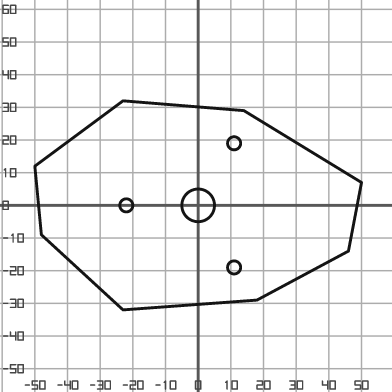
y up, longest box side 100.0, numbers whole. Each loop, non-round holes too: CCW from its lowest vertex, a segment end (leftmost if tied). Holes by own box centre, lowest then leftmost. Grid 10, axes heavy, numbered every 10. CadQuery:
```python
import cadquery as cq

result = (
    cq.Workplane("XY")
    .moveTo(-23.0, -32.0)
    .lineTo(18.0, -29.0)
    .lineTo(46.0, -14.0)
    .lineTo(50.0, 7.0)
    .lineTo(14.0, 29.0)
    .lineTo(-23.0, 32.0)
    .lineTo(-50.0, 12.0)
    .lineTo(-48.0, -9.0)
    .close()
    .moveTo(11.0, -19.0)
    .circle(2.0)
    .moveTo(-22.0, 0.0)
    .circle(2.0)
    .moveTo(0.0, 0.0)
    .circle(5.0)
    .moveTo(11.0, 19.0)
    .circle(2.0)
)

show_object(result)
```